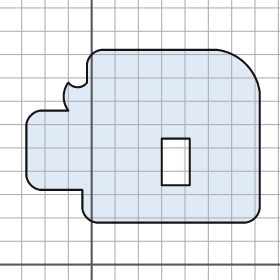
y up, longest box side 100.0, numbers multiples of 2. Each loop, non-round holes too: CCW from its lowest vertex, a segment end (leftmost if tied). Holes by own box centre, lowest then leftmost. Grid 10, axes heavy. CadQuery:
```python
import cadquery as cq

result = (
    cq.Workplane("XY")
    .moveTo(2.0, 18.0)
    .lineTo(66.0, 18.0)
    .threePointArc((70.0, 20.0), (72.0, 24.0))
    .lineTo(72.0, 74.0)
    .threePointArc((66.0, 86.0), (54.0, 92.0))
    .lineTo(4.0, 92.0)
    .threePointArc((0.0, 90.0), (-2.0, 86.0))
    .lineTo(-2.0, 78.0)
    .threePointArc((-6.0, 76.0), (-10.0, 78.0))
    .threePointArc((-12.0, 72.0), (-10.0, 66.0))
    .lineTo(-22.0, 66.0)
    .threePointArc((-26.0, 64.0), (-28.0, 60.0))
    .lineTo(-28.0, 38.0)
    .threePointArc((-26.0, 34.0), (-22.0, 32.0))
    .lineTo(-4.0, 32.0)
    .lineTo(-4.0, 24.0)
    .threePointArc((-2.0, 20.0), (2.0, 18.0))
    .close()
    .moveTo(30.0, 34.0)
    .lineTo(42.0, 34.0)
    .lineTo(42.0, 54.0)
    .lineTo(30.0, 54.0)
    .close()
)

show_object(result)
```